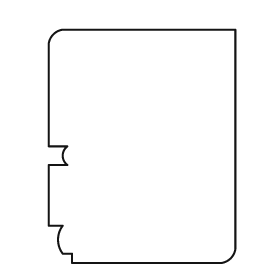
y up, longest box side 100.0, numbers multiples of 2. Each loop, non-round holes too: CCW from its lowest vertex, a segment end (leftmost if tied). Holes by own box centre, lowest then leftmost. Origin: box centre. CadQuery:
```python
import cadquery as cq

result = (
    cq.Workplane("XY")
    .moveTo(-30.0, -50.0)
    .lineTo(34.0, -50.0)
    .threePointArc((38.0, -48.0), (40.0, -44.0))
    .lineTo(40.0, 50.0)
    .lineTo(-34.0, 50.0)
    .threePointArc((-38.0, 48.0), (-40.0, 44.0))
    .lineTo(-40.0, 0.0)
    .lineTo(-32.0, 0.0)
    .threePointArc((-34.0, -4.0), (-32.0, -8.0))
    .lineTo(-40.0, -8.0)
    .lineTo(-40.0, -34.0)
    .lineTo(-34.0, -34.0)
    .threePointArc((-36.0, -40.0), (-34.0, -46.0))
    .lineTo(-30.0, -46.0)
    .close()
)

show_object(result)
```